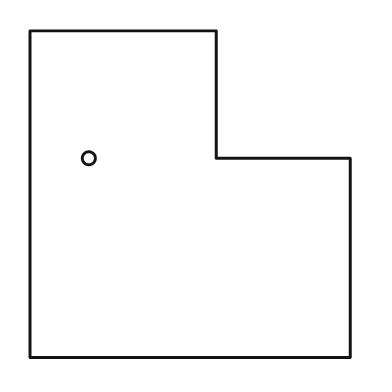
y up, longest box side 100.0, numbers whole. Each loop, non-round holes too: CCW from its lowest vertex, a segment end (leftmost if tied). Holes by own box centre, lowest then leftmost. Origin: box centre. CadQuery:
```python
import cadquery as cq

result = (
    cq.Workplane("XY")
    .moveTo(-49.0, -50.0)
    .lineTo(49.0, -50.0)
    .lineTo(49.0, 11.0)
    .lineTo(8.0, 11.0)
    .lineTo(8.0, 50.0)
    .lineTo(-49.0, 50.0)
    .close()
    .moveTo(-31.0, 11.0)
    .circle(2.0)
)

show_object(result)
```